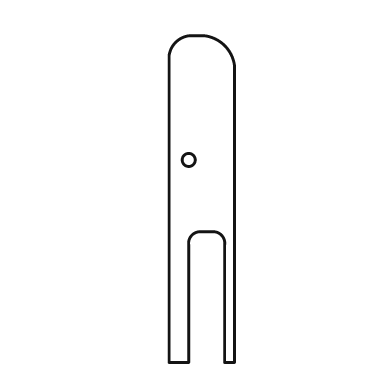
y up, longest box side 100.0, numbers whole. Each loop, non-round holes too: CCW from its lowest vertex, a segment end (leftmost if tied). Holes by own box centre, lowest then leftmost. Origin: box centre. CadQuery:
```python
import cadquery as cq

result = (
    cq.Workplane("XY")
    .moveTo(-10.0, -50.0)
    .lineTo(-4.0, -50.0)
    .lineTo(-4.0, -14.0)
    .threePointArc((-3.0, -11.0), (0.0, -10.0))
    .lineTo(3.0, -10.0)
    .threePointArc((6.0, -11.0), (7.0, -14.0))
    .lineTo(7.0, -50.0)
    .lineTo(10.0, -50.0)
    .lineTo(10.0, 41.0)
    .threePointArc((7.0, 47.0), (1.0, 50.0))
    .lineTo(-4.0, 50.0)
    .threePointArc((-8.0, 48.0), (-10.0, 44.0))
    .close()
    .moveTo(-4.0, 12.0)
    .circle(2.0)
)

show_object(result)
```